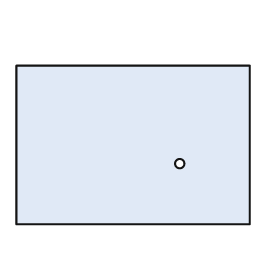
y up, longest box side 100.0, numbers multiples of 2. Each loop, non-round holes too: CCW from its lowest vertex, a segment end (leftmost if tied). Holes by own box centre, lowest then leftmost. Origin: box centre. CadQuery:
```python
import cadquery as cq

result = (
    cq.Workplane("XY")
    .moveTo(-50.0, -34.0)
    .lineTo(50.0, -34.0)
    .lineTo(50.0, 34.0)
    .lineTo(-50.0, 34.0)
    .close()
    .moveTo(20.0, -8.0)
    .circle(2.0)
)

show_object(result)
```